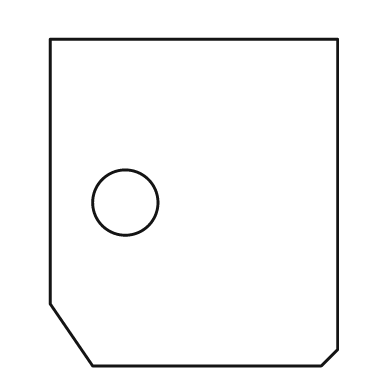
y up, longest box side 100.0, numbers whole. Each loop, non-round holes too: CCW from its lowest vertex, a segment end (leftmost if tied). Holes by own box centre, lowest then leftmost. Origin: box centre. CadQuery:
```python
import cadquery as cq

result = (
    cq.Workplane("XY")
    .moveTo(-31.0, -50.0)
    .lineTo(39.0, -50.0)
    .lineTo(44.0, -45.0)
    .lineTo(44.0, 50.0)
    .lineTo(-44.0, 50.0)
    .lineTo(-44.0, -31.0)
    .close()
    .moveTo(-21.0, 0.0)
    .circle(10.0)
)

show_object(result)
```